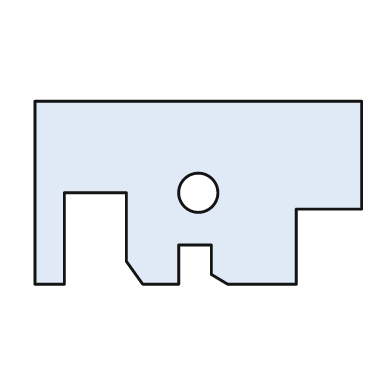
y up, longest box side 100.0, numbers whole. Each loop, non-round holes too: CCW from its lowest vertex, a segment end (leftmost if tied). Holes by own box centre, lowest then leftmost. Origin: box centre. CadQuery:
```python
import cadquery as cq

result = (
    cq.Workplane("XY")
    .moveTo(-50.0, -28.0)
    .lineTo(-41.0, -28.0)
    .lineTo(-41.0, 0.0)
    .lineTo(-22.0, 0.0)
    .lineTo(-22.0, -21.0)
    .lineTo(-17.0, -28.0)
    .lineTo(-6.0, -28.0)
    .lineTo(-6.0, -16.0)
    .lineTo(4.0, -16.0)
    .lineTo(4.0, -25.0)
    .lineTo(9.0, -28.0)
    .lineTo(30.0, -28.0)
    .lineTo(30.0, -5.0)
    .lineTo(50.0, -5.0)
    .lineTo(50.0, 28.0)
    .lineTo(-50.0, 28.0)
    .close()
    .moveTo(0.0, 0.0)
    .circle(6.0)
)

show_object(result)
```